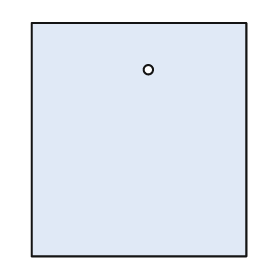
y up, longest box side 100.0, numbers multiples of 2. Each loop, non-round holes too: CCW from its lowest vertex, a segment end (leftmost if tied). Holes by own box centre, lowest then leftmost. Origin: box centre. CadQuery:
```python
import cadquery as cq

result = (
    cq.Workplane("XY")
    .moveTo(-46.0, -50.0)
    .lineTo(46.0, -50.0)
    .lineTo(46.0, 50.0)
    .lineTo(-46.0, 50.0)
    .close()
    .moveTo(4.0, 30.0)
    .circle(2.0)
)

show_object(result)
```